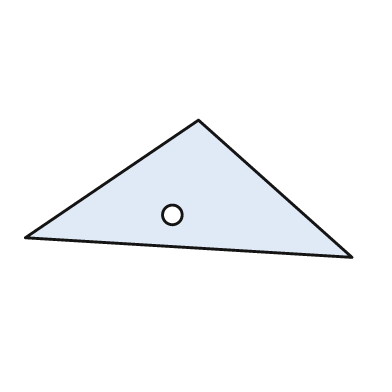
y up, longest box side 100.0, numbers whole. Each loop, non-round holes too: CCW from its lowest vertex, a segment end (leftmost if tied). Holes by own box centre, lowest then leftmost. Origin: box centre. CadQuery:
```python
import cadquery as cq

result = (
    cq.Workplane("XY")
    .moveTo(50.0, -21.0)
    .lineTo(3.0, 21.0)
    .lineTo(-50.0, -15.0)
    .close()
    .moveTo(-5.0, -8.0)
    .circle(3.0)
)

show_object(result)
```